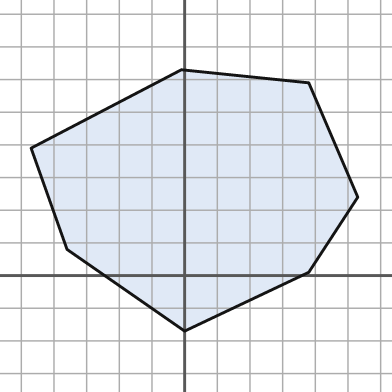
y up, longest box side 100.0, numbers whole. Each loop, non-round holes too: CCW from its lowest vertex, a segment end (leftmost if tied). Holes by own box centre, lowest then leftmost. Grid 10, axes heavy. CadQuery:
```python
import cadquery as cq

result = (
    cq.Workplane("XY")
    .moveTo(0.0, -17.0)
    .lineTo(38.0, 1.0)
    .lineTo(53.0, 24.0)
    .lineTo(38.0, 59.0)
    .lineTo(-1.0, 63.0)
    .lineTo(-47.0, 39.0)
    .lineTo(-36.0, 8.0)
    .close()
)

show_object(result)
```